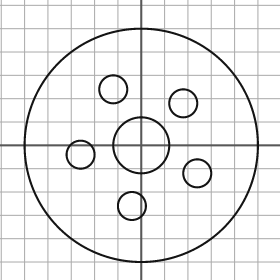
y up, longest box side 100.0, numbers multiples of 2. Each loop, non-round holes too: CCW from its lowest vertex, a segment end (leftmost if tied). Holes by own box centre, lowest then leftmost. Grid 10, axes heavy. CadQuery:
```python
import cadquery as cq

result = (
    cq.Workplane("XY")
    .moveTo(0.0, 0.0)
    .circle(50.0)
    .moveTo(-4.0, -26.0)
    .circle(6.0)
    .moveTo(24.0, -12.0)
    .circle(6.0)
    .moveTo(-26.0, -4.0)
    .circle(6.0)
    .moveTo(0.0, 0.0)
    .circle(12.0)
    .moveTo(18.0, 18.0)
    .circle(6.0)
    .moveTo(-12.0, 24.0)
    .circle(6.0)
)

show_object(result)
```